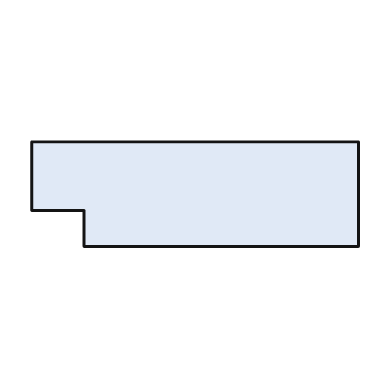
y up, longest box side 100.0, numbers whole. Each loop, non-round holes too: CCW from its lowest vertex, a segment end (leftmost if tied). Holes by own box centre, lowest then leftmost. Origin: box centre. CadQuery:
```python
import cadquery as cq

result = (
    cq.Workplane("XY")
    .moveTo(-34.0, -16.0)
    .lineTo(50.0, -16.0)
    .lineTo(50.0, 16.0)
    .lineTo(-50.0, 16.0)
    .lineTo(-50.0, -5.0)
    .lineTo(-34.0, -5.0)
    .close()
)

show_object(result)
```